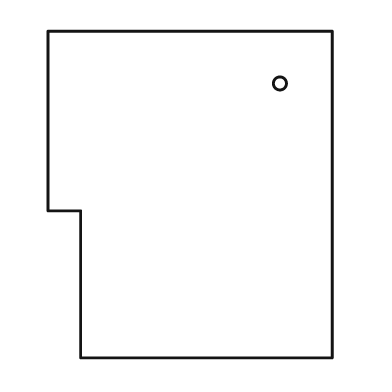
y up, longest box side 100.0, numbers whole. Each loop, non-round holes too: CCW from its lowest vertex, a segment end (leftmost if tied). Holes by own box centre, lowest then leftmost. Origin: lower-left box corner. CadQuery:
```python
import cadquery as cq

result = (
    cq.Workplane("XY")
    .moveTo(10.0, 0.0)
    .lineTo(87.0, 0.0)
    .lineTo(87.0, 100.0)
    .lineTo(0.0, 100.0)
    .lineTo(0.0, 45.0)
    .lineTo(10.0, 45.0)
    .close()
    .moveTo(71.0, 84.0)
    .circle(2.0)
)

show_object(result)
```